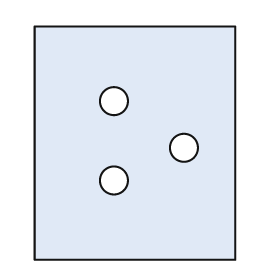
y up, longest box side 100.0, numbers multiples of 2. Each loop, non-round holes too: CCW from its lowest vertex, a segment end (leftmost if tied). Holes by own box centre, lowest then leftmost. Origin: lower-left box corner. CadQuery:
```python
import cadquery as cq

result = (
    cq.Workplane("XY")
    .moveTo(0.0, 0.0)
    .lineTo(86.0, 0.0)
    .lineTo(86.0, 100.0)
    .lineTo(0.0, 100.0)
    .close()
    .moveTo(34.0, 34.0)
    .circle(6.0)
    .moveTo(64.0, 48.0)
    .circle(6.0)
    .moveTo(34.0, 68.0)
    .circle(6.0)
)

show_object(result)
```